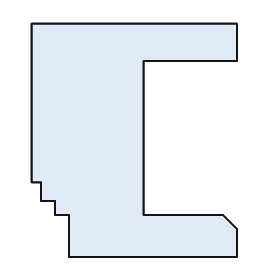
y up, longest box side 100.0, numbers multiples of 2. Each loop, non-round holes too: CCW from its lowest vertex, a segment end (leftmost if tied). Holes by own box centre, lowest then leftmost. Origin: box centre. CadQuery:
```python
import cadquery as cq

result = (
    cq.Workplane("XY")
    .moveTo(-28.0, -50.0)
    .lineTo(44.0, -50.0)
    .lineTo(44.0, -38.0)
    .lineTo(38.0, -32.0)
    .lineTo(4.0, -32.0)
    .lineTo(4.0, 34.0)
    .lineTo(44.0, 34.0)
    .lineTo(44.0, 50.0)
    .lineTo(-44.0, 50.0)
    .lineTo(-44.0, -18.0)
    .lineTo(-40.0, -18.0)
    .lineTo(-40.0, -26.0)
    .lineTo(-34.0, -26.0)
    .lineTo(-34.0, -32.0)
    .lineTo(-28.0, -32.0)
    .close()
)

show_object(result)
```